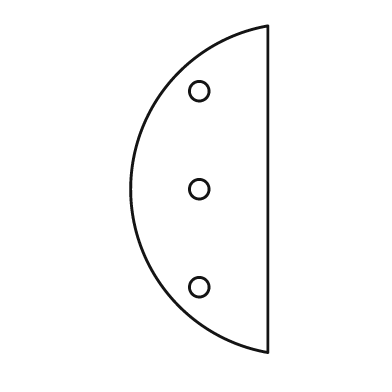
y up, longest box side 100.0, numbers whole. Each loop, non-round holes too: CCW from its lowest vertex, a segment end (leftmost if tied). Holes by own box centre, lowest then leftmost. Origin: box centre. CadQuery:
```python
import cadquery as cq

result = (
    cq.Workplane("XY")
    .moveTo(21.0, -50.0)
    .lineTo(21.0, 50.0)
    .threePointArc((-21.0, 0.0), (21.0, -50.0))
    .close()
    .moveTo(0.0, -30.0)
    .circle(3.0)
    .moveTo(0.0, 0.0)
    .circle(3.0)
    .moveTo(0.0, 30.0)
    .circle(3.0)
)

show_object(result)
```